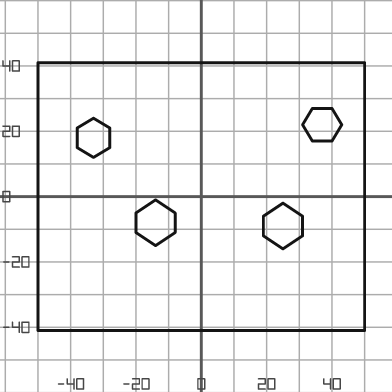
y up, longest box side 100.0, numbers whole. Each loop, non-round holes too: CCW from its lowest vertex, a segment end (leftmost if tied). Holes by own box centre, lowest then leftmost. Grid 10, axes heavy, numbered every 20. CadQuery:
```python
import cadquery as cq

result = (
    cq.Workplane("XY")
    .moveTo(-50.0, -41.0)
    .lineTo(50.0, -41.0)
    .lineTo(50.0, 41.0)
    .lineTo(-50.0, 41.0)
    .close()
    .moveTo(25.0, -16.0)
    .lineTo(31.0, -12.0)
    .lineTo(31.0, -6.0)
    .lineTo(25.0, -2.0)
    .lineTo(19.0, -6.0)
    .lineTo(19.0, -12.0)
    .close()
    .moveTo(-14.0, -15.0)
    .lineTo(-8.0, -11.0)
    .lineTo(-8.0, -5.0)
    .lineTo(-14.0, -1.0)
    .lineTo(-20.0, -5.0)
    .lineTo(-20.0, -11.0)
    .close()
    .moveTo(-33.0, 12.0)
    .lineTo(-28.0, 15.0)
    .lineTo(-28.0, 21.0)
    .lineTo(-33.0, 24.0)
    .lineTo(-38.0, 21.0)
    .lineTo(-38.0, 15.0)
    .close()
    .moveTo(34.0, 17.0)
    .lineTo(40.0, 17.0)
    .lineTo(43.0, 22.0)
    .lineTo(40.0, 27.0)
    .lineTo(34.0, 27.0)
    .lineTo(31.0, 22.0)
    .close()
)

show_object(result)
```